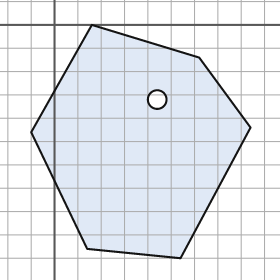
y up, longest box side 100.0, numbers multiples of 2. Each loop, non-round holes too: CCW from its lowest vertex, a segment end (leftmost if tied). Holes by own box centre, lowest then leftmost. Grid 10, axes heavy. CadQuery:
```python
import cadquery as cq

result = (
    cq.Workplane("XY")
    .moveTo(54.0, -100.0)
    .lineTo(84.0, -44.0)
    .lineTo(62.0, -14.0)
    .lineTo(16.0, 0.0)
    .lineTo(-10.0, -46.0)
    .lineTo(14.0, -96.0)
    .close()
    .moveTo(44.0, -32.0)
    .circle(4.0)
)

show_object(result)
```